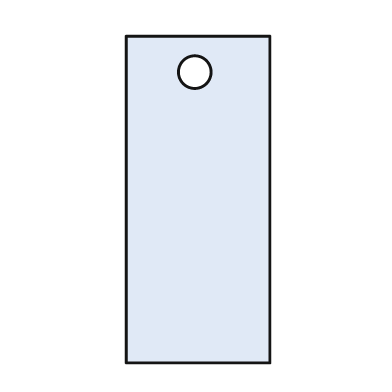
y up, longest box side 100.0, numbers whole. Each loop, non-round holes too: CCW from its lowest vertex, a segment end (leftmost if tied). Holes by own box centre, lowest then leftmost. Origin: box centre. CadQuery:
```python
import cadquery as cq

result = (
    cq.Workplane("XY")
    .moveTo(-22.0, -50.0)
    .lineTo(22.0, -50.0)
    .lineTo(22.0, 50.0)
    .lineTo(-22.0, 50.0)
    .close()
    .moveTo(-1.0, 39.0)
    .circle(5.0)
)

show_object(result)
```